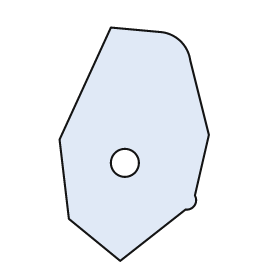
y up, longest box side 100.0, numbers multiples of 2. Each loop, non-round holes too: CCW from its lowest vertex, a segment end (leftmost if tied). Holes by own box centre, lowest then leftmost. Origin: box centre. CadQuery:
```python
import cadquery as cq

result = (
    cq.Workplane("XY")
    .moveTo(-6.0, -50.0)
    .lineTo(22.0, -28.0)
    .threePointArc((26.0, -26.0), (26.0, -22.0))
    .lineTo(32.0, 4.0)
    .lineTo(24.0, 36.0)
    .threePointArc((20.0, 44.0), (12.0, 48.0))
    .lineTo(-10.0, 50.0)
    .lineTo(-32.0, 2.0)
    .lineTo(-28.0, -32.0)
    .close()
    .moveTo(-4.0, -8.0)
    .circle(6.0)
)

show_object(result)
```